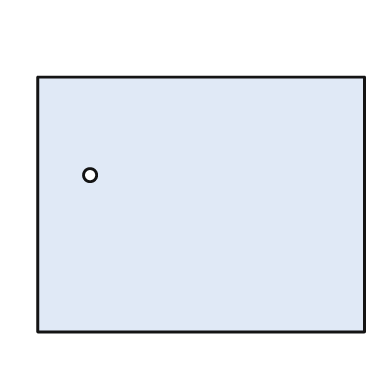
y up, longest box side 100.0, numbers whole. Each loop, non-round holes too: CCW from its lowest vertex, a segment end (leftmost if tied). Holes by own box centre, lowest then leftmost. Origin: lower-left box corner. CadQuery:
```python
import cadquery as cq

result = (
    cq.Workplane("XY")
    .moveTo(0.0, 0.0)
    .lineTo(100.0, 0.0)
    .lineTo(100.0, 78.0)
    .lineTo(0.0, 78.0)
    .close()
    .moveTo(16.0, 48.0)
    .circle(2.0)
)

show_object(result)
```